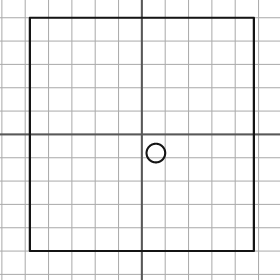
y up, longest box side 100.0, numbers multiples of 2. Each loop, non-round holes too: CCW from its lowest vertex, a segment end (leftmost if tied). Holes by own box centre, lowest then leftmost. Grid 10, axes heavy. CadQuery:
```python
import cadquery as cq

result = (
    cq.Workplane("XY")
    .moveTo(-48.0, -50.0)
    .lineTo(48.0, -50.0)
    .lineTo(48.0, 50.0)
    .lineTo(-48.0, 50.0)
    .close()
    .moveTo(6.0, -8.0)
    .circle(4.0)
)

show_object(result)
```